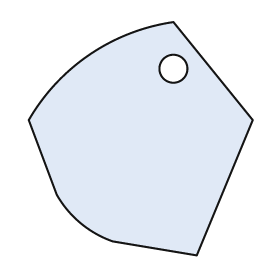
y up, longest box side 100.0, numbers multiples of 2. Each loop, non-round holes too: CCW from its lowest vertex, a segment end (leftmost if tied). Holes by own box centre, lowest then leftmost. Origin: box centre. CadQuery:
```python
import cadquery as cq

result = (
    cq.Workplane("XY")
    .moveTo(24.0, -50.0)
    .lineTo(48.0, 8.0)
    .lineTo(14.0, 50.0)
    .threePointArc((-22.0, 36.0), (-48.0, 8.0))
    .lineTo(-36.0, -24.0)
    .threePointArc((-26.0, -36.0), (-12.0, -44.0))
    .close()
    .moveTo(14.0, 30.0)
    .circle(6.0)
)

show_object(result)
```